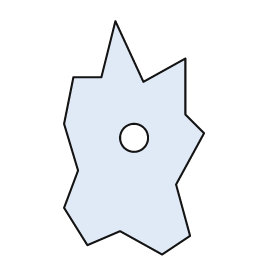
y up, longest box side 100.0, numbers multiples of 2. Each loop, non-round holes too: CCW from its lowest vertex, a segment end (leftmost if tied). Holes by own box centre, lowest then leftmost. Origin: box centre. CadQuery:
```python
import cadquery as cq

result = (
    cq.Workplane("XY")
    .moveTo(12.0, -50.0)
    .lineTo(24.0, -42.0)
    .lineTo(18.0, -20.0)
    .lineTo(30.0, 2.0)
    .lineTo(22.0, 10.0)
    .lineTo(22.0, 34.0)
    .lineTo(4.0, 24.0)
    .lineTo(-8.0, 50.0)
    .lineTo(-14.0, 26.0)
    .lineTo(-26.0, 26.0)
    .lineTo(-30.0, 6.0)
    .lineTo(-24.0, -14.0)
    .lineTo(-30.0, -30.0)
    .lineTo(-20.0, -46.0)
    .lineTo(-6.0, -40.0)
    .close()
    .moveTo(0.0, 0.0)
    .circle(6.0)
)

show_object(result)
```